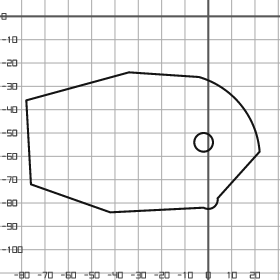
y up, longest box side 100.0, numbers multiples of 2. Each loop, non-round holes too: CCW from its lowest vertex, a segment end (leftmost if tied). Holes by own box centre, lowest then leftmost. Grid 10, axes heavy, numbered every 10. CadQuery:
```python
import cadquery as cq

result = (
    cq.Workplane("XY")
    .moveTo(-42.0, -84.0)
    .lineTo(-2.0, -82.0)
    .threePointArc((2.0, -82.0), (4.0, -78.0))
    .lineTo(22.0, -58.0)
    .threePointArc((14.0, -38.0), (-4.0, -26.0))
    .lineTo(-34.0, -24.0)
    .lineTo(-78.0, -36.0)
    .lineTo(-76.0, -72.0)
    .close()
    .moveTo(-2.0, -54.0)
    .circle(4.0)
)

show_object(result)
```